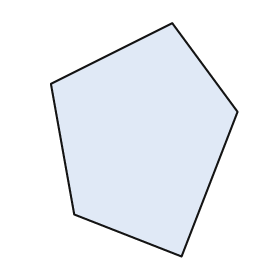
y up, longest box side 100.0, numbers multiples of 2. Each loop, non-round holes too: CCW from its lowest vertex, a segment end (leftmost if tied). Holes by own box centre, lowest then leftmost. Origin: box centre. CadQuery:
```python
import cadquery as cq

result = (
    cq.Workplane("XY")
    .moveTo(16.0, -50.0)
    .lineTo(40.0, 12.0)
    .lineTo(12.0, 50.0)
    .lineTo(-40.0, 24.0)
    .lineTo(-30.0, -32.0)
    .close()
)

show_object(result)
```